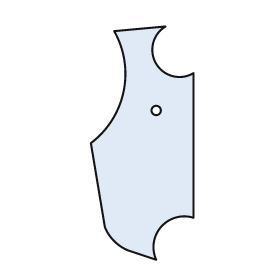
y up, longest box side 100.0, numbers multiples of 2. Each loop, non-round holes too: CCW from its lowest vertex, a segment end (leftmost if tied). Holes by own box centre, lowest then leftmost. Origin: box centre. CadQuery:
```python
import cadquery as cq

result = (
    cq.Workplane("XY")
    .moveTo(6.0, -50.0)
    .threePointArc((8.0, -36.0), (22.0, -32.0))
    .lineTo(22.0, 30.0)
    .threePointArc((6.0, 34.0), (10.0, 50.0))
    .lineTo(-12.0, 48.0)
    .threePointArc((-8.0, 22.0), (-22.0, 0.0))
    .lineTo(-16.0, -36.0)
    .threePointArc((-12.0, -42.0), (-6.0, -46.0))
    .close()
    .moveTo(6.0, 14.0)
    .circle(2.0)
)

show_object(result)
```